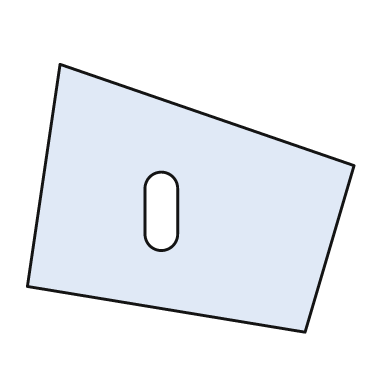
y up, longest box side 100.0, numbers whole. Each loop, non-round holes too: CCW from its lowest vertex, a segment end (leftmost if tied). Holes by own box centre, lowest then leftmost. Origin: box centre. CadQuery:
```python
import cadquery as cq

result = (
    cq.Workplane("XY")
    .moveTo(35.0, -41.0)
    .lineTo(50.0, 10.0)
    .lineTo(-40.0, 41.0)
    .lineTo(-50.0, -27.0)
    .close()
    .moveTo(-14.0, -11.0)
    .threePointArc((-9.0, -16.0), (-4.0, -11.0))
    .lineTo(-4.0, 3.0)
    .threePointArc((-9.0, 8.0), (-14.0, 3.0))
    .close()
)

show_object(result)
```